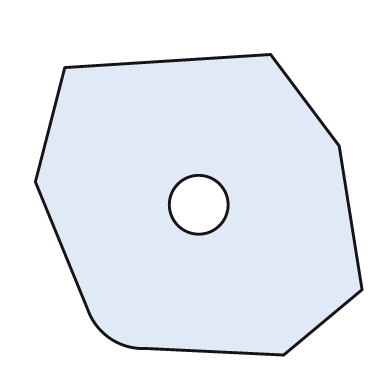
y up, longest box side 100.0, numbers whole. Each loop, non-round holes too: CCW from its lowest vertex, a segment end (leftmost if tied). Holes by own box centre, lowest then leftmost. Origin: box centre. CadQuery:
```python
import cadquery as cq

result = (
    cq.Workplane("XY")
    .moveTo(26.0, -46.0)
    .lineTo(50.0, -26.0)
    .lineTo(43.0, 18.0)
    .lineTo(22.0, 46.0)
    .lineTo(-41.0, 42.0)
    .lineTo(-50.0, 7.0)
    .lineTo(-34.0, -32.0)
    .threePointArc((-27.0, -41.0), (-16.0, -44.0))
    .close()
    .moveTo(0.0, 0.0)
    .circle(9.0)
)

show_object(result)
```